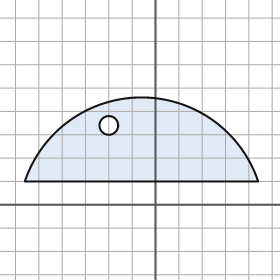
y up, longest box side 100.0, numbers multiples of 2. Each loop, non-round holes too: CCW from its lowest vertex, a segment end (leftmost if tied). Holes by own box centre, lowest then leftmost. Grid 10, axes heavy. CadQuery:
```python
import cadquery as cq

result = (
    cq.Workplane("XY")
    .moveTo(-56.0, 10.0)
    .lineTo(44.0, 10.0)
    .threePointArc((-6.0, 46.0), (-56.0, 10.0))
    .close()
    .moveTo(-20.0, 34.0)
    .circle(4.0)
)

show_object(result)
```